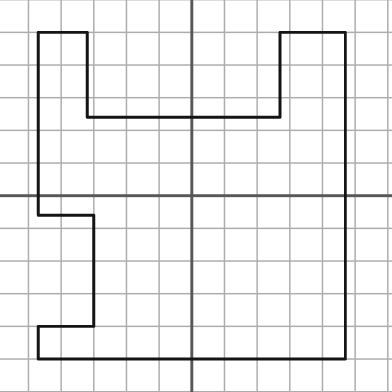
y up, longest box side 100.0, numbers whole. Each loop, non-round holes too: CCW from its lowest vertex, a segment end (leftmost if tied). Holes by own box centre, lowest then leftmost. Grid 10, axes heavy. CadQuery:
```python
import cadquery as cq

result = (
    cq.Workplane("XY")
    .moveTo(-47.0, -50.0)
    .lineTo(47.0, -50.0)
    .lineTo(47.0, 50.0)
    .lineTo(27.0, 50.0)
    .lineTo(27.0, 24.0)
    .lineTo(-32.0, 24.0)
    .lineTo(-32.0, 50.0)
    .lineTo(-47.0, 50.0)
    .lineTo(-47.0, -6.0)
    .lineTo(-30.0, -6.0)
    .lineTo(-30.0, -40.0)
    .lineTo(-47.0, -40.0)
    .close()
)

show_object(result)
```